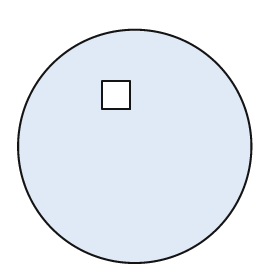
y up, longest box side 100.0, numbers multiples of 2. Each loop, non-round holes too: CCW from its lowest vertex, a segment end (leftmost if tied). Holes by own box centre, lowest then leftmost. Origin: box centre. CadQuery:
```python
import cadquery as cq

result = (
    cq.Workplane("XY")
    .moveTo(0.0, 0.0)
    .circle(50.0)
    .moveTo(-14.0, 16.0)
    .lineTo(-2.0, 16.0)
    .lineTo(-2.0, 28.0)
    .lineTo(-14.0, 28.0)
    .close()
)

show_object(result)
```